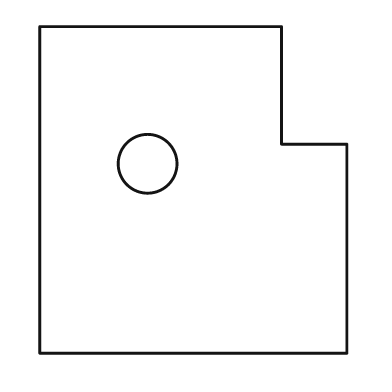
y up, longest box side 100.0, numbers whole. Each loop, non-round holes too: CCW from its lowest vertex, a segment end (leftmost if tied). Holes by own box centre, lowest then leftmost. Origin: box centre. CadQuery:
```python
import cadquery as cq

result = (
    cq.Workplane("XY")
    .moveTo(-47.0, -50.0)
    .lineTo(47.0, -50.0)
    .lineTo(47.0, 14.0)
    .lineTo(27.0, 14.0)
    .lineTo(27.0, 50.0)
    .lineTo(-47.0, 50.0)
    .close()
    .moveTo(-14.0, 8.0)
    .circle(9.0)
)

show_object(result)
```